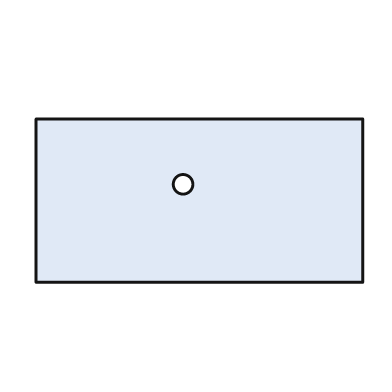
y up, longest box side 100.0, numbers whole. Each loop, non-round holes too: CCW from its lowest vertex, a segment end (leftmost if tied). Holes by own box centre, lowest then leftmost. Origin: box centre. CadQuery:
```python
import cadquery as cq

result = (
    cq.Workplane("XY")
    .moveTo(-50.0, -25.0)
    .lineTo(50.0, -25.0)
    .lineTo(50.0, 25.0)
    .lineTo(-50.0, 25.0)
    .close()
    .moveTo(-5.0, 5.0)
    .circle(3.0)
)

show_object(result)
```